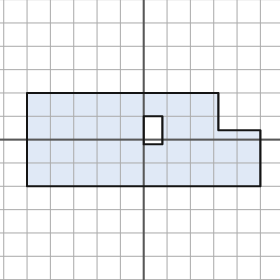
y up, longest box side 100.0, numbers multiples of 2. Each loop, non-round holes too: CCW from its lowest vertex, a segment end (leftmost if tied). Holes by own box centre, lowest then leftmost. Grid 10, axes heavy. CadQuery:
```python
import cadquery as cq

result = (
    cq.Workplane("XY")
    .moveTo(-50.0, -20.0)
    .lineTo(50.0, -20.0)
    .lineTo(50.0, 4.0)
    .lineTo(32.0, 4.0)
    .lineTo(32.0, 20.0)
    .lineTo(-50.0, 20.0)
    .close()
    .moveTo(0.0, -2.0)
    .lineTo(8.0, -2.0)
    .lineTo(8.0, 10.0)
    .lineTo(0.0, 10.0)
    .close()
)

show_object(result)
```